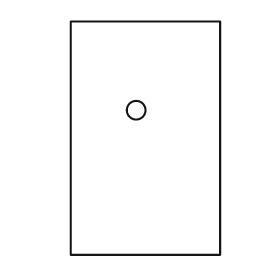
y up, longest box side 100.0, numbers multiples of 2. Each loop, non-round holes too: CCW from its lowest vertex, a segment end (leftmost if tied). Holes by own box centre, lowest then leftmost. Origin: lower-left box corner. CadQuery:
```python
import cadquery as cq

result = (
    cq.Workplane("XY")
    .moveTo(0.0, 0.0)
    .lineTo(64.0, 0.0)
    .lineTo(64.0, 100.0)
    .lineTo(0.0, 100.0)
    .close()
    .moveTo(28.0, 62.0)
    .circle(4.0)
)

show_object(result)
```